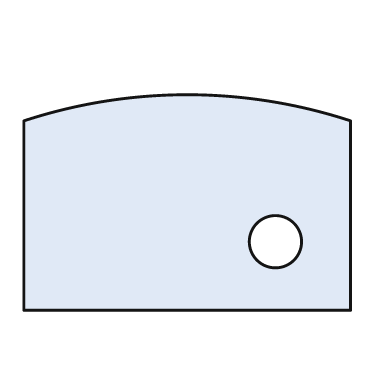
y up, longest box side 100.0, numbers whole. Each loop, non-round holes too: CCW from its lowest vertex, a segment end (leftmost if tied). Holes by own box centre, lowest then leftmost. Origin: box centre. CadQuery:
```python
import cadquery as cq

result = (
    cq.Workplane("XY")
    .moveTo(-50.0, -33.0)
    .lineTo(50.0, -33.0)
    .lineTo(50.0, 25.0)
    .threePointArc((0.0, 33.0), (-50.0, 25.0))
    .close()
    .moveTo(27.0, -12.0)
    .circle(8.0)
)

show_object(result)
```